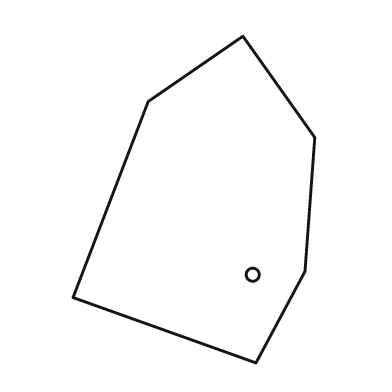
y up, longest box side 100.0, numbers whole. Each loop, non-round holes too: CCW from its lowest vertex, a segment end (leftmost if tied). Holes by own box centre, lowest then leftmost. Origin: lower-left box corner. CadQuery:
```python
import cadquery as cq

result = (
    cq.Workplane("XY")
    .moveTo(56.0, 0.0)
    .lineTo(71.0, 28.0)
    .lineTo(74.0, 69.0)
    .lineTo(52.0, 100.0)
    .lineTo(23.0, 80.0)
    .lineTo(0.0, 20.0)
    .close()
    .moveTo(55.0, 27.0)
    .circle(2.0)
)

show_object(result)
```